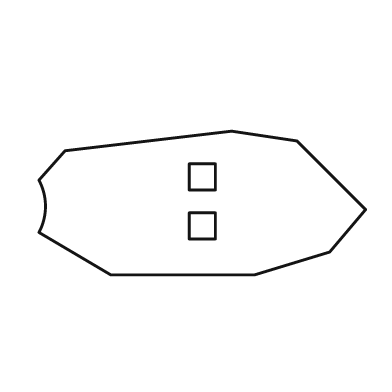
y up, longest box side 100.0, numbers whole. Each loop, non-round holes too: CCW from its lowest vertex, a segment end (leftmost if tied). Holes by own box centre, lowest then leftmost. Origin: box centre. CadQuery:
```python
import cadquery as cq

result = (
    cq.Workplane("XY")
    .moveTo(-28.0, -22.0)
    .lineTo(16.0, -22.0)
    .lineTo(39.0, -15.0)
    .lineTo(50.0, -2.0)
    .lineTo(29.0, 19.0)
    .lineTo(9.0, 22.0)
    .lineTo(-42.0, 16.0)
    .lineTo(-50.0, 7.0)
    .threePointArc((-48.0, -1.0), (-50.0, -9.0))
    .close()
    .moveTo(-4.0, -11.0)
    .lineTo(4.0, -11.0)
    .lineTo(4.0, -3.0)
    .lineTo(-4.0, -3.0)
    .close()
    .moveTo(-4.0, 4.0)
    .lineTo(4.0, 4.0)
    .lineTo(4.0, 12.0)
    .lineTo(-4.0, 12.0)
    .close()
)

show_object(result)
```